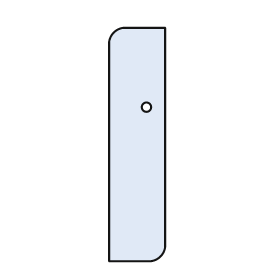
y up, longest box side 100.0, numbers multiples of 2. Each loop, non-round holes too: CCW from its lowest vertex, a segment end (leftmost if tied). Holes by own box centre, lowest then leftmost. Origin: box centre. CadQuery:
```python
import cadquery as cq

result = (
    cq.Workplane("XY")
    .moveTo(-12.0, -50.0)
    .lineTo(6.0, -50.0)
    .threePointArc((10.0, -48.0), (12.0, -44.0))
    .lineTo(12.0, 50.0)
    .lineTo(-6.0, 50.0)
    .threePointArc((-10.0, 48.0), (-12.0, 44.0))
    .close()
    .moveTo(4.0, 16.0)
    .circle(2.0)
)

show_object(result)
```